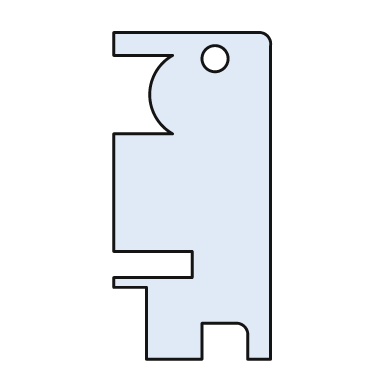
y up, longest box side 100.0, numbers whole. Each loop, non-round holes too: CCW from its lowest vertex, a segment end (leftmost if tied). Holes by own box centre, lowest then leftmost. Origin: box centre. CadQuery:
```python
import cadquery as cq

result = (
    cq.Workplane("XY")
    .moveTo(-14.0, -50.0)
    .lineTo(3.0, -50.0)
    .lineTo(3.0, -39.0)
    .lineTo(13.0, -39.0)
    .threePointArc((16.0, -40.0), (17.0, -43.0))
    .lineTo(17.0, -50.0)
    .lineTo(24.0, -50.0)
    .lineTo(24.0, 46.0)
    .threePointArc((23.0, 49.0), (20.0, 50.0))
    .lineTo(-24.0, 50.0)
    .lineTo(-24.0, 43.0)
    .lineTo(-6.0, 43.0)
    .threePointArc((-13.0, 31.0), (-6.0, 19.0))
    .lineTo(-24.0, 19.0)
    .lineTo(-24.0, -17.0)
    .lineTo(0.0, -17.0)
    .lineTo(0.0, -25.0)
    .lineTo(-24.0, -25.0)
    .lineTo(-24.0, -28.0)
    .lineTo(-14.0, -28.0)
    .close()
    .moveTo(7.0, 42.0)
    .circle(4.0)
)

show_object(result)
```